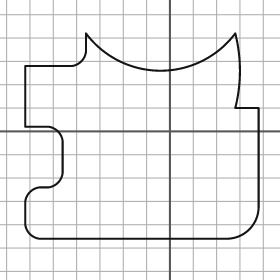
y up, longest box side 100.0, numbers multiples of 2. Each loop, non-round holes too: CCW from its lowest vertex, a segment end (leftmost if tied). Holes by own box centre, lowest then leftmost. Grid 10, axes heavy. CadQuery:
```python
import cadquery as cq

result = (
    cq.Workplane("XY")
    .moveTo(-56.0, -46.0)
    .lineTo(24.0, -46.0)
    .threePointArc((34.0, -42.0), (38.0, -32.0))
    .lineTo(38.0, 10.0)
    .lineTo(28.0, 10.0)
    .threePointArc((30.0, 26.0), (28.0, 42.0))
    .threePointArc((-4.0, 26.0), (-36.0, 42.0))
    .lineTo(-36.0, 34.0)
    .threePointArc((-38.0, 30.0), (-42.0, 28.0))
    .lineTo(-62.0, 28.0)
    .lineTo(-62.0, 2.0)
    .lineTo(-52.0, 2.0)
    .threePointArc((-48.0, 0.0), (-46.0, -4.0))
    .lineTo(-46.0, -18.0)
    .threePointArc((-48.0, -22.0), (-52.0, -24.0))
    .lineTo(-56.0, -24.0)
    .threePointArc((-60.0, -26.0), (-62.0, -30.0))
    .lineTo(-62.0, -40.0)
    .threePointArc((-60.0, -44.0), (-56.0, -46.0))
    .close()
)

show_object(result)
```